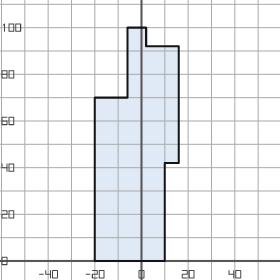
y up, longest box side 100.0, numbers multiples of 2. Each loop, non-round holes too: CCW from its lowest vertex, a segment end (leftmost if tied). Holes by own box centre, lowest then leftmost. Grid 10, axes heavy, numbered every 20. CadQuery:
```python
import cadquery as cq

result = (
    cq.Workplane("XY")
    .moveTo(-20.0, 0.0)
    .lineTo(10.0, 0.0)
    .lineTo(10.0, 42.0)
    .lineTo(16.0, 42.0)
    .lineTo(16.0, 92.0)
    .lineTo(2.0, 92.0)
    .lineTo(2.0, 100.0)
    .lineTo(-6.0, 100.0)
    .lineTo(-6.0, 70.0)
    .lineTo(-20.0, 70.0)
    .close()
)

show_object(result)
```